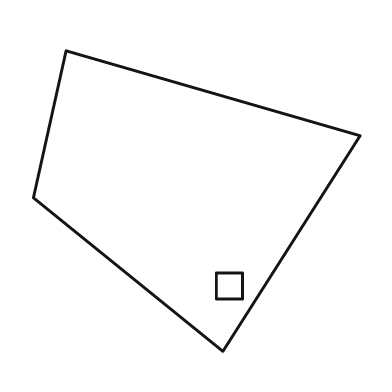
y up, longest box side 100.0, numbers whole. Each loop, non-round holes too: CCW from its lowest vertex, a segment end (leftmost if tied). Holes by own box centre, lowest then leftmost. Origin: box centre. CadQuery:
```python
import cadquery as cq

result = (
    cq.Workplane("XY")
    .moveTo(8.0, -46.0)
    .lineTo(50.0, 20.0)
    .lineTo(-40.0, 46.0)
    .lineTo(-50.0, 1.0)
    .close()
    .moveTo(6.0, -30.0)
    .lineTo(14.0, -30.0)
    .lineTo(14.0, -22.0)
    .lineTo(6.0, -22.0)
    .close()
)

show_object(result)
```